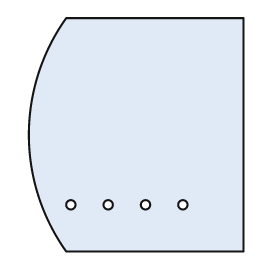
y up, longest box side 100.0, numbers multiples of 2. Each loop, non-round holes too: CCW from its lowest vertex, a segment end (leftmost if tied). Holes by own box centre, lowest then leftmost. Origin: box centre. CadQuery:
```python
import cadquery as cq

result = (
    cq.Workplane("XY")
    .moveTo(-30.0, -50.0)
    .lineTo(46.0, -50.0)
    .lineTo(46.0, 50.0)
    .lineTo(-30.0, 50.0)
    .threePointArc((-46.0, 0.0), (-30.0, -50.0))
    .close()
    .moveTo(-28.0, -30.0)
    .circle(2.0)
    .moveTo(-12.0, -30.0)
    .circle(2.0)
    .moveTo(4.0, -30.0)
    .circle(2.0)
    .moveTo(20.0, -30.0)
    .circle(2.0)
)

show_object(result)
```